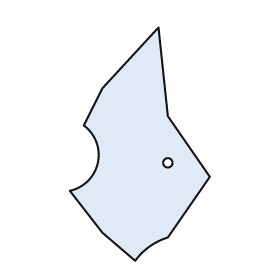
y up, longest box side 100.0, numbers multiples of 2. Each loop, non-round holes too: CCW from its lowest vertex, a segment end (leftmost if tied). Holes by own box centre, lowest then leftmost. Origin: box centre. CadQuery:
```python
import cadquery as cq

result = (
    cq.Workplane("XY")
    .moveTo(-2.0, -50.0)
    .threePointArc((4.0, -44.0), (12.0, -40.0))
    .lineTo(30.0, -14.0)
    .lineTo(12.0, 12.0)
    .lineTo(8.0, 50.0)
    .lineTo(-16.0, 24.0)
    .lineTo(-24.0, 8.0)
    .threePointArc((-18.0, -8.0), (-30.0, -20.0))
    .lineTo(-16.0, -38.0)
    .close()
    .moveTo(12.0, -8.0)
    .circle(2.0)
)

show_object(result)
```